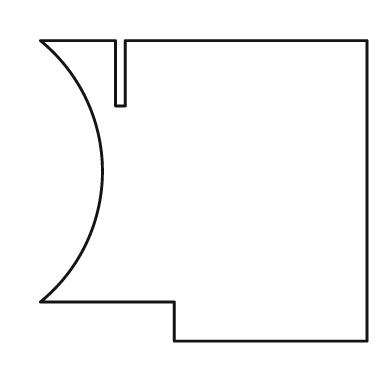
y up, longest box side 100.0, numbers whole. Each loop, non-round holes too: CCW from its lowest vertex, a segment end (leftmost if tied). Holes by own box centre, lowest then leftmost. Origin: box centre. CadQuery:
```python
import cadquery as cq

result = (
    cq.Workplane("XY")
    .moveTo(-9.0, -46.0)
    .lineTo(50.0, -46.0)
    .lineTo(50.0, 46.0)
    .lineTo(-24.0, 46.0)
    .lineTo(-24.0, 26.0)
    .lineTo(-27.0, 26.0)
    .lineTo(-27.0, 46.0)
    .lineTo(-50.0, 46.0)
    .threePointArc((-31.0, 6.0), (-50.0, -34.0))
    .lineTo(-9.0, -34.0)
    .close()
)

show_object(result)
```